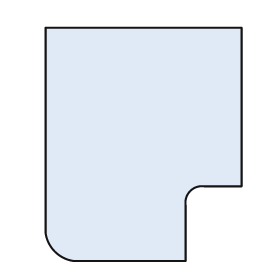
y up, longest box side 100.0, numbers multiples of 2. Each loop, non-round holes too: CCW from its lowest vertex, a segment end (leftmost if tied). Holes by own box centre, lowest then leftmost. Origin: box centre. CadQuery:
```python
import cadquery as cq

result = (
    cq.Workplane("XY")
    .moveTo(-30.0, -50.0)
    .lineTo(18.0, -50.0)
    .lineTo(18.0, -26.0)
    .threePointArc((20.0, -20.0), (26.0, -18.0))
    .lineTo(42.0, -18.0)
    .lineTo(42.0, 50.0)
    .lineTo(-42.0, 50.0)
    .lineTo(-42.0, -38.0)
    .threePointArc((-38.0, -46.0), (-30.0, -50.0))
    .close()
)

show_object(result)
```